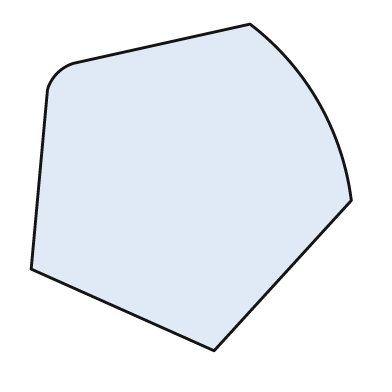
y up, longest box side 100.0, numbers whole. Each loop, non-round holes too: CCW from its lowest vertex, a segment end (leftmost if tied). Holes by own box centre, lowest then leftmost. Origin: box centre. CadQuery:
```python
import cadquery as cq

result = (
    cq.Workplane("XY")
    .moveTo(7.0, -50.0)
    .lineTo(49.0, -4.0)
    .threePointArc((39.0, 26.0), (18.0, 50.0))
    .lineTo(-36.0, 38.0)
    .threePointArc((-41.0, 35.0), (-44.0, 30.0))
    .lineTo(-49.0, -25.0)
    .close()
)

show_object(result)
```